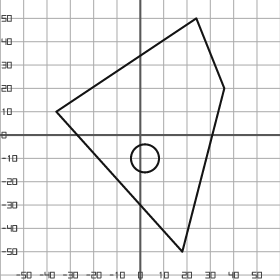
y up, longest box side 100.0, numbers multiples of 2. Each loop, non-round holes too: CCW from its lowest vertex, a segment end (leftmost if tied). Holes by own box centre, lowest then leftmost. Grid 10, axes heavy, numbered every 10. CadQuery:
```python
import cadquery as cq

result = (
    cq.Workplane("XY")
    .moveTo(18.0, -50.0)
    .lineTo(36.0, 20.0)
    .lineTo(24.0, 50.0)
    .lineTo(-36.0, 10.0)
    .close()
    .moveTo(2.0, -10.0)
    .circle(6.0)
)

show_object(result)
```